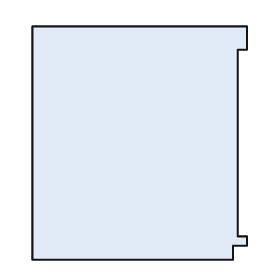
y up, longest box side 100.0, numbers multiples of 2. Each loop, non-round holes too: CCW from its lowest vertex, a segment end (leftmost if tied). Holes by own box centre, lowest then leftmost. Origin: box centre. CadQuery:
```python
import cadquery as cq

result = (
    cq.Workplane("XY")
    .moveTo(-46.0, -50.0)
    .lineTo(40.0, -50.0)
    .lineTo(40.0, -44.0)
    .lineTo(46.0, -44.0)
    .lineTo(46.0, -40.0)
    .lineTo(42.0, -40.0)
    .lineTo(42.0, 40.0)
    .lineTo(46.0, 40.0)
    .lineTo(46.0, 50.0)
    .lineTo(-46.0, 50.0)
    .close()
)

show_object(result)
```